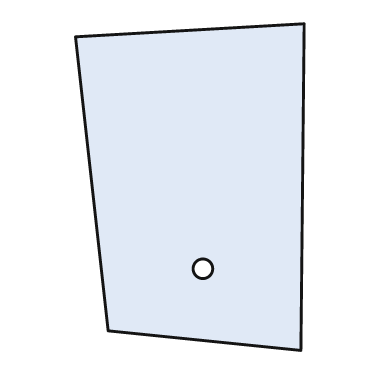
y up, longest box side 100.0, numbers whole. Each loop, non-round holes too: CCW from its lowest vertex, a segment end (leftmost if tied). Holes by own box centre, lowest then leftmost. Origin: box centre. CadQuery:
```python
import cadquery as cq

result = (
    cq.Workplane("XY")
    .moveTo(34.0, -50.0)
    .lineTo(35.0, 50.0)
    .lineTo(-35.0, 46.0)
    .lineTo(-25.0, -44.0)
    .close()
    .moveTo(4.0, -25.0)
    .circle(3.0)
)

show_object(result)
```